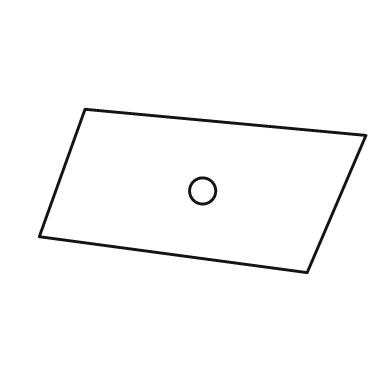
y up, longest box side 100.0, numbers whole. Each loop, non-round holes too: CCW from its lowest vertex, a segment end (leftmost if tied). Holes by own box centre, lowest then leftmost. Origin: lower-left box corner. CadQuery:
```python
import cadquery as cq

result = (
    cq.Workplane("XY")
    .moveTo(82.0, 0.0)
    .lineTo(100.0, 42.0)
    .lineTo(14.0, 50.0)
    .lineTo(0.0, 11.0)
    .close()
    .moveTo(50.0, 25.0)
    .circle(4.0)
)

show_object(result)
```